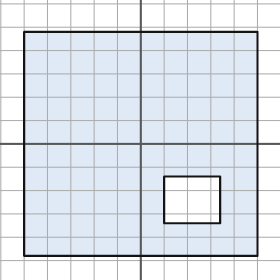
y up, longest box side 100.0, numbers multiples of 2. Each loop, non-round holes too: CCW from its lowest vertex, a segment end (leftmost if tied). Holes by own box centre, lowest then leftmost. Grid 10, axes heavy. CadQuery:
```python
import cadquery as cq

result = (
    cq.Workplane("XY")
    .moveTo(-50.0, -48.0)
    .lineTo(50.0, -48.0)
    .lineTo(50.0, 48.0)
    .lineTo(-50.0, 48.0)
    .close()
    .moveTo(10.0, -34.0)
    .lineTo(34.0, -34.0)
    .lineTo(34.0, -14.0)
    .lineTo(10.0, -14.0)
    .close()
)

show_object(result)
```